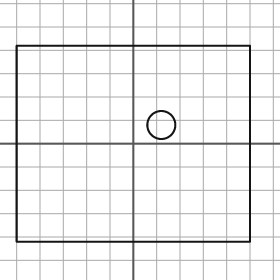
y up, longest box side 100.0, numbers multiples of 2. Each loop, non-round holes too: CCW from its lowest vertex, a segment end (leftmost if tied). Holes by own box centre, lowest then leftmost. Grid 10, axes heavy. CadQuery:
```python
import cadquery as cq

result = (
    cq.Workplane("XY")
    .moveTo(-50.0, -42.0)
    .lineTo(50.0, -42.0)
    .lineTo(50.0, 42.0)
    .lineTo(-50.0, 42.0)
    .close()
    .moveTo(12.0, 8.0)
    .circle(6.0)
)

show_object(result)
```